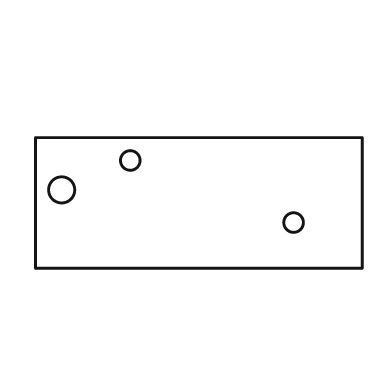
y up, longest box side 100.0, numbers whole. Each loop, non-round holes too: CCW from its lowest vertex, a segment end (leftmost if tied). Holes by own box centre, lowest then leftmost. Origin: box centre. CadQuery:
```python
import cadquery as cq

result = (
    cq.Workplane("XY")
    .moveTo(-50.0, -20.0)
    .lineTo(50.0, -20.0)
    .lineTo(50.0, 20.0)
    .lineTo(-50.0, 20.0)
    .close()
    .moveTo(29.0, -6.0)
    .circle(3.0)
    .moveTo(-42.0, 4.0)
    .circle(4.0)
    .moveTo(-21.0, 13.0)
    .circle(3.0)
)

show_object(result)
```